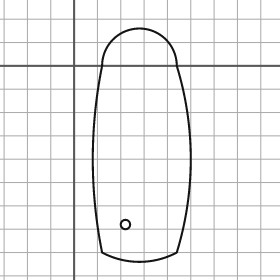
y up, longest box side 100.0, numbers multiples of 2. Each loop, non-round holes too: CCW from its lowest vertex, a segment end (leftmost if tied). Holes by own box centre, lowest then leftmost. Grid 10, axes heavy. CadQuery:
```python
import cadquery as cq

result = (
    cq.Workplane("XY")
    .moveTo(12.0, -80.0)
    .threePointArc((28.0, -84.0), (44.0, -80.0))
    .threePointArc((50.0, -40.0), (44.0, 0.0))
    .threePointArc((28.0, 16.0), (12.0, 0.0))
    .threePointArc((8.0, -40.0), (12.0, -80.0))
    .close()
    .moveTo(22.0, -68.0)
    .circle(2.0)
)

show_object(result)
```